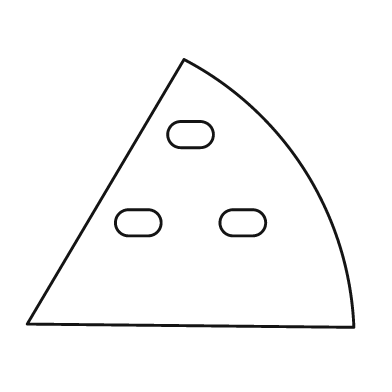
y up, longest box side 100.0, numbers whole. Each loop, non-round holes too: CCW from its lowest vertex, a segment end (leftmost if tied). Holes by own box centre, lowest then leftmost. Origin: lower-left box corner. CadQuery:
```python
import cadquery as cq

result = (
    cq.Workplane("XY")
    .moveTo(100.0, 0.0)
    .threePointArc((85.0, 48.0), (48.0, 82.0))
    .lineTo(0.0, 1.0)
    .close()
    .moveTo(31.0, 28.0)
    .lineTo(37.0, 28.0)
    .threePointArc((41.0, 32.0), (37.0, 36.0))
    .lineTo(31.0, 36.0)
    .threePointArc((27.0, 32.0), (31.0, 28.0))
    .close()
    .moveTo(63.0, 28.0)
    .lineTo(69.0, 28.0)
    .threePointArc((73.0, 32.0), (69.0, 36.0))
    .lineTo(63.0, 36.0)
    .threePointArc((59.0, 32.0), (63.0, 28.0))
    .close()
    .moveTo(47.0, 55.0)
    .lineTo(53.0, 55.0)
    .threePointArc((57.0, 59.0), (53.0, 63.0))
    .lineTo(47.0, 63.0)
    .threePointArc((43.0, 59.0), (47.0, 55.0))
    .close()
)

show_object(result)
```